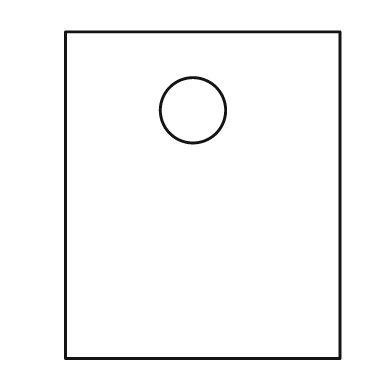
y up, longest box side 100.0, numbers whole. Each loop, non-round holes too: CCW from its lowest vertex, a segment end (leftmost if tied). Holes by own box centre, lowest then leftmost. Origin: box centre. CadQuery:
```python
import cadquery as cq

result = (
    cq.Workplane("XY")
    .moveTo(-42.0, -50.0)
    .lineTo(42.0, -50.0)
    .lineTo(42.0, 50.0)
    .lineTo(-42.0, 50.0)
    .close()
    .moveTo(-3.0, 26.0)
    .circle(10.0)
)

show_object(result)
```